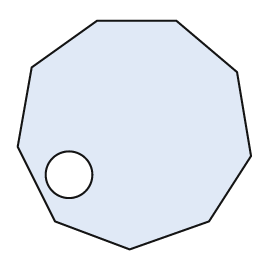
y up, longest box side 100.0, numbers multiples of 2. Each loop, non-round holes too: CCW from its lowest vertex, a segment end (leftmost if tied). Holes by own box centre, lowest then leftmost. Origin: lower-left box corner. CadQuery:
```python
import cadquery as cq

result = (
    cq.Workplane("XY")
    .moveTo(48.0, 0.0)
    .lineTo(82.0, 12.0)
    .lineTo(100.0, 40.0)
    .lineTo(94.0, 76.0)
    .lineTo(68.0, 98.0)
    .lineTo(34.0, 98.0)
    .lineTo(6.0, 78.0)
    .lineTo(0.0, 44.0)
    .lineTo(16.0, 12.0)
    .close()
    .moveTo(22.0, 32.0)
    .circle(10.0)
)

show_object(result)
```